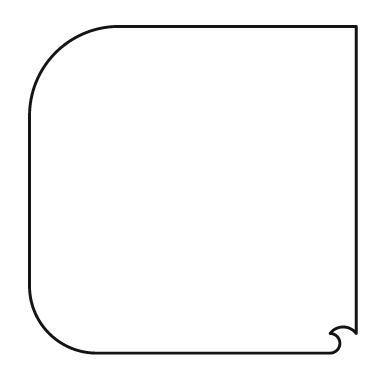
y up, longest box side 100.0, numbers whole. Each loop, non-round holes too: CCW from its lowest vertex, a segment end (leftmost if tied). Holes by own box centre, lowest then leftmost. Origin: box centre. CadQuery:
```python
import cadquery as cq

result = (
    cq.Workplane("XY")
    .moveTo(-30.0, -50.0)
    .lineTo(42.0, -50.0)
    .threePointArc((45.0, -47.0), (42.0, -44.0))
    .threePointArc((46.0, -42.0), (50.0, -44.0))
    .lineTo(50.0, 50.0)
    .lineTo(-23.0, 50.0)
    .threePointArc((-42.0, 42.0), (-50.0, 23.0))
    .lineTo(-50.0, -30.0)
    .threePointArc((-44.0, -44.0), (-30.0, -50.0))
    .close()
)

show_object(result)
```